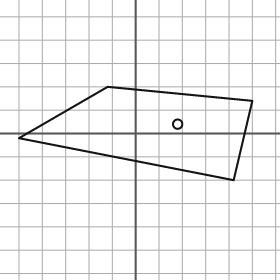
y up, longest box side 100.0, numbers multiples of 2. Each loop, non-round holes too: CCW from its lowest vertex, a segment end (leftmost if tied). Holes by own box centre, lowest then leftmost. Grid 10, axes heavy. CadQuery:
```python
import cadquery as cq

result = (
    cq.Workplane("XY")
    .moveTo(42.0, -20.0)
    .lineTo(50.0, 14.0)
    .lineTo(-12.0, 20.0)
    .lineTo(-50.0, -2.0)
    .close()
    .moveTo(18.0, 4.0)
    .circle(2.0)
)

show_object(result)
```